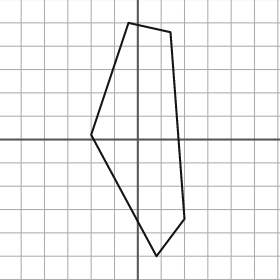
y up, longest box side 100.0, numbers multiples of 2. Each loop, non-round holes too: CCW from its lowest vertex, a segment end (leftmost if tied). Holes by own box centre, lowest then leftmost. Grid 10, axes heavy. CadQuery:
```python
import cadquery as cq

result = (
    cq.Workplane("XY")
    .moveTo(8.0, -50.0)
    .lineTo(20.0, -34.0)
    .lineTo(14.0, 46.0)
    .lineTo(-4.0, 50.0)
    .lineTo(-20.0, 2.0)
    .close()
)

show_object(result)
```